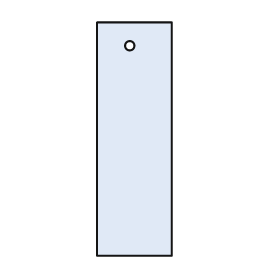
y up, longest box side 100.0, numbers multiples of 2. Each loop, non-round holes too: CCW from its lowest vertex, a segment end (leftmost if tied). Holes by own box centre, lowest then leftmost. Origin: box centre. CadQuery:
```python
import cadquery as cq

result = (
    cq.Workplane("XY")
    .moveTo(-16.0, -50.0)
    .lineTo(16.0, -50.0)
    .lineTo(16.0, 50.0)
    .lineTo(-16.0, 50.0)
    .close()
    .moveTo(-2.0, 40.0)
    .circle(2.0)
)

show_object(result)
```